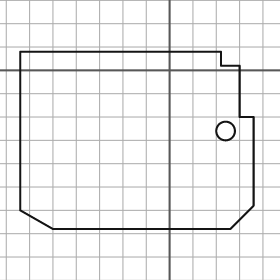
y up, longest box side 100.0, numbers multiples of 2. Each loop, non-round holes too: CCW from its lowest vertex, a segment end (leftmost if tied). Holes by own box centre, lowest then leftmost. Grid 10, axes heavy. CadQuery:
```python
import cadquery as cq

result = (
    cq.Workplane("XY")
    .moveTo(-50.0, -68.0)
    .lineTo(26.0, -68.0)
    .lineTo(36.0, -58.0)
    .lineTo(36.0, -20.0)
    .lineTo(30.0, -20.0)
    .lineTo(30.0, 2.0)
    .lineTo(22.0, 2.0)
    .lineTo(22.0, 8.0)
    .lineTo(-64.0, 8.0)
    .lineTo(-64.0, -60.0)
    .close()
    .moveTo(24.0, -26.0)
    .circle(4.0)
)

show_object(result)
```